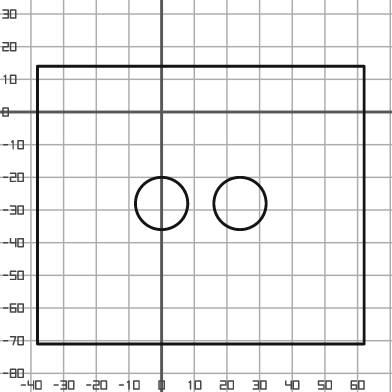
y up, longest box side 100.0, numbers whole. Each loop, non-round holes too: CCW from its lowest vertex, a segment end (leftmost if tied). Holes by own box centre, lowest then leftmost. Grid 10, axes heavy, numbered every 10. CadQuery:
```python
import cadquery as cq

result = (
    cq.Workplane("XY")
    .moveTo(-38.0, -71.0)
    .lineTo(62.0, -71.0)
    .lineTo(62.0, 14.0)
    .lineTo(-38.0, 14.0)
    .close()
    .moveTo(0.0, -28.0)
    .circle(8.0)
    .moveTo(24.0, -28.0)
    .circle(8.0)
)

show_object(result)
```